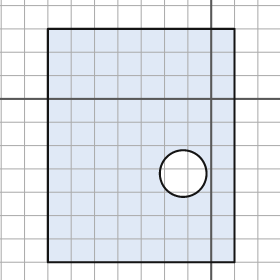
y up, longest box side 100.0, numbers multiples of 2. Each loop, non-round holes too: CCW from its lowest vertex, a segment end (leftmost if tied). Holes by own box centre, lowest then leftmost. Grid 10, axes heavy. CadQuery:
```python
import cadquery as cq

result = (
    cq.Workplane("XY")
    .moveTo(-70.0, -70.0)
    .lineTo(10.0, -70.0)
    .lineTo(10.0, 30.0)
    .lineTo(-70.0, 30.0)
    .close()
    .moveTo(-12.0, -32.0)
    .circle(10.0)
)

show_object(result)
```